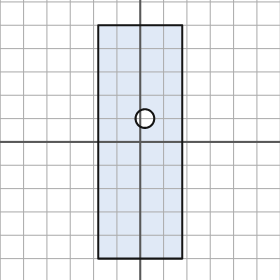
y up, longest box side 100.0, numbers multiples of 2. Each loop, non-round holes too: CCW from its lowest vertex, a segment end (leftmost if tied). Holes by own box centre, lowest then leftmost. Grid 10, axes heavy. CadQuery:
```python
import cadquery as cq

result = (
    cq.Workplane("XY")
    .moveTo(-18.0, -50.0)
    .lineTo(18.0, -50.0)
    .lineTo(18.0, 50.0)
    .lineTo(-18.0, 50.0)
    .close()
    .moveTo(2.0, 10.0)
    .circle(4.0)
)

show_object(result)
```